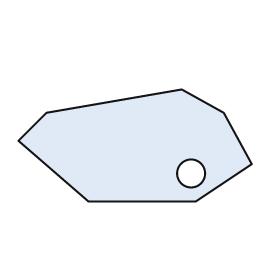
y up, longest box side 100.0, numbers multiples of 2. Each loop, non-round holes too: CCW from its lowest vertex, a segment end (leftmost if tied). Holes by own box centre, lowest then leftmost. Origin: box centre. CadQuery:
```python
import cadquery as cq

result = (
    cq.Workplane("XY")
    .moveTo(-20.0, -24.0)
    .lineTo(26.0, -24.0)
    .lineTo(50.0, -8.0)
    .lineTo(38.0, 14.0)
    .lineTo(20.0, 24.0)
    .lineTo(-38.0, 14.0)
    .lineTo(-50.0, 2.0)
    .close()
    .moveTo(24.0, -12.0)
    .circle(6.0)
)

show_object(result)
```